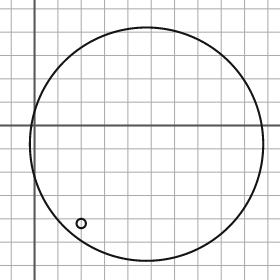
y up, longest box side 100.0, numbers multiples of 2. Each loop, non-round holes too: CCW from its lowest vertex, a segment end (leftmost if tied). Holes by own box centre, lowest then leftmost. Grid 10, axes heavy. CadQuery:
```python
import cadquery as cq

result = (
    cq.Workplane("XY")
    .moveTo(48.0, -8.0)
    .circle(50.0)
    .moveTo(20.0, -42.0)
    .circle(2.0)
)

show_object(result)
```